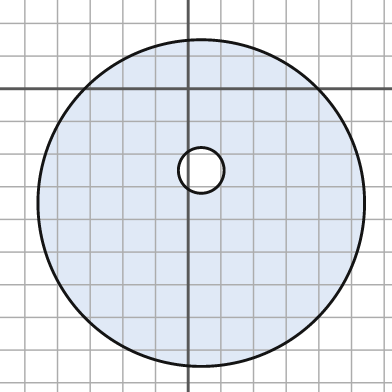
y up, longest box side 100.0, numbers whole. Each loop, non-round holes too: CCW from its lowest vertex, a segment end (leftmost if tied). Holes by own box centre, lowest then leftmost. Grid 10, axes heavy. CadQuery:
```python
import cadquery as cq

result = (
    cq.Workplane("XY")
    .moveTo(4.0, -35.0)
    .circle(50.0)
    .moveTo(4.0, -25.0)
    .circle(7.0)
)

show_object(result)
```